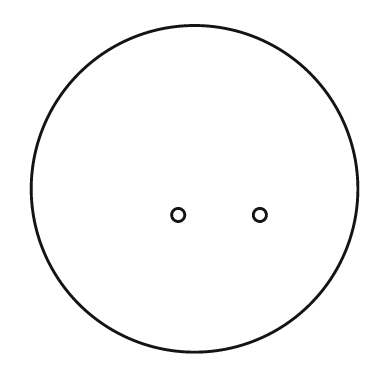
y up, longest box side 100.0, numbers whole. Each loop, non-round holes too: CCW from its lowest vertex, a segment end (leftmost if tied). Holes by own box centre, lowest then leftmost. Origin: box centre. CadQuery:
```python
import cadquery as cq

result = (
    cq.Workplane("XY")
    .moveTo(0.0, 0.0)
    .circle(50.0)
    .moveTo(-5.0, -8.0)
    .circle(2.0)
    .moveTo(20.0, -8.0)
    .circle(2.0)
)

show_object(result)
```